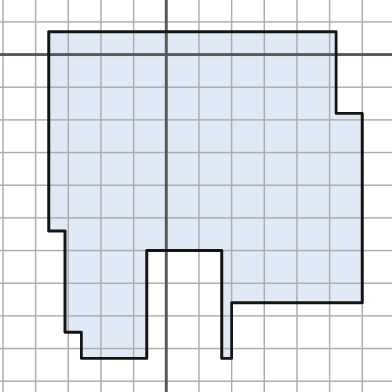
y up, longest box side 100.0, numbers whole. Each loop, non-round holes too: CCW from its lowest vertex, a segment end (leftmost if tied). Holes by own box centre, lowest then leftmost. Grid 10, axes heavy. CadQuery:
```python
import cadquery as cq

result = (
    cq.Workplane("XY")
    .moveTo(-26.0, -93.0)
    .lineTo(-6.0, -93.0)
    .lineTo(-6.0, -60.0)
    .lineTo(17.0, -60.0)
    .lineTo(17.0, -93.0)
    .lineTo(20.0, -93.0)
    .lineTo(20.0, -76.0)
    .lineTo(60.0, -76.0)
    .lineTo(60.0, -18.0)
    .lineTo(52.0, -18.0)
    .lineTo(52.0, 7.0)
    .lineTo(-36.0, 7.0)
    .lineTo(-36.0, -54.0)
    .lineTo(-31.0, -54.0)
    .lineTo(-31.0, -85.0)
    .lineTo(-26.0, -85.0)
    .close()
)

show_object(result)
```